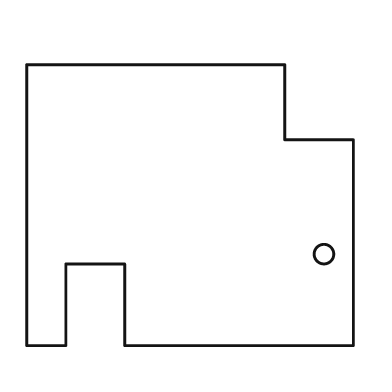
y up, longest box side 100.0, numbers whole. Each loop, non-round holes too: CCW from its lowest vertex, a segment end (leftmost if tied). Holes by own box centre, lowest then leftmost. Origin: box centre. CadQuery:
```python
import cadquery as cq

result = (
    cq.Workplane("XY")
    .moveTo(-50.0, -43.0)
    .lineTo(-38.0, -43.0)
    .lineTo(-38.0, -18.0)
    .lineTo(-20.0, -18.0)
    .lineTo(-20.0, -43.0)
    .lineTo(50.0, -43.0)
    .lineTo(50.0, 20.0)
    .lineTo(29.0, 20.0)
    .lineTo(29.0, 43.0)
    .lineTo(-50.0, 43.0)
    .close()
    .moveTo(41.0, -15.0)
    .circle(3.0)
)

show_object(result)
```